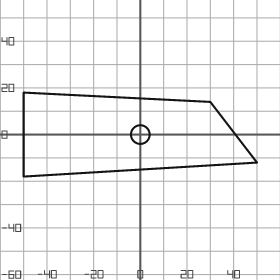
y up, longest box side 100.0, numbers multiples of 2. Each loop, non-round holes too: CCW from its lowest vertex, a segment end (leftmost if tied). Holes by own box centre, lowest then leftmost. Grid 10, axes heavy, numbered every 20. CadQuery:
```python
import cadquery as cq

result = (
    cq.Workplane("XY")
    .moveTo(-50.0, -18.0)
    .lineTo(50.0, -12.0)
    .lineTo(30.0, 14.0)
    .lineTo(-50.0, 18.0)
    .close()
    .moveTo(0.0, 0.0)
    .circle(4.0)
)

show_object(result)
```